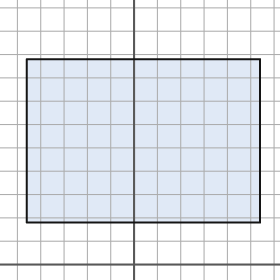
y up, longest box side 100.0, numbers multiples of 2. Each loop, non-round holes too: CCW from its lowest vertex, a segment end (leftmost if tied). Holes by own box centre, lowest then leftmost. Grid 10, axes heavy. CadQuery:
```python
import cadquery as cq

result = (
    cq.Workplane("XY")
    .moveTo(-46.0, 18.0)
    .lineTo(54.0, 18.0)
    .lineTo(54.0, 88.0)
    .lineTo(-46.0, 88.0)
    .close()
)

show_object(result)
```